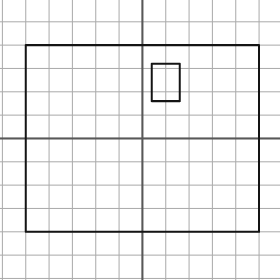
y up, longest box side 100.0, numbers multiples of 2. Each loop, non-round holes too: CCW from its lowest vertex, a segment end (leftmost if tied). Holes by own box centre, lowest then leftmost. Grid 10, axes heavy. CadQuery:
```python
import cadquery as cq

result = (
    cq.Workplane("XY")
    .moveTo(-50.0, -40.0)
    .lineTo(50.0, -40.0)
    .lineTo(50.0, 40.0)
    .lineTo(-50.0, 40.0)
    .close()
    .moveTo(4.0, 16.0)
    .lineTo(16.0, 16.0)
    .lineTo(16.0, 32.0)
    .lineTo(4.0, 32.0)
    .close()
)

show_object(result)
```